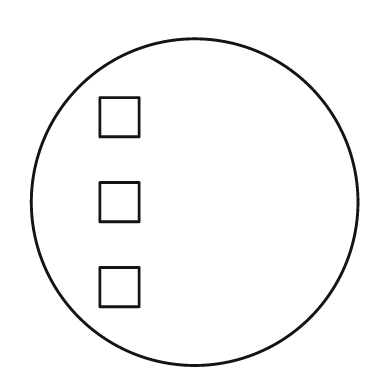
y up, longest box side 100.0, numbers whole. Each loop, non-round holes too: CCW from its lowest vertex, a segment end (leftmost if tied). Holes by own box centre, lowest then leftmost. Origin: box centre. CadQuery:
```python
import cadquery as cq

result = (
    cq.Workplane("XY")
    .moveTo(0.0, 0.0)
    .circle(50.0)
    .moveTo(-29.0, -32.0)
    .lineTo(-17.0, -32.0)
    .lineTo(-17.0, -20.0)
    .lineTo(-29.0, -20.0)
    .close()
    .moveTo(-29.0, -6.0)
    .lineTo(-17.0, -6.0)
    .lineTo(-17.0, 6.0)
    .lineTo(-29.0, 6.0)
    .close()
    .moveTo(-29.0, 20.0)
    .lineTo(-17.0, 20.0)
    .lineTo(-17.0, 32.0)
    .lineTo(-29.0, 32.0)
    .close()
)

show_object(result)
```